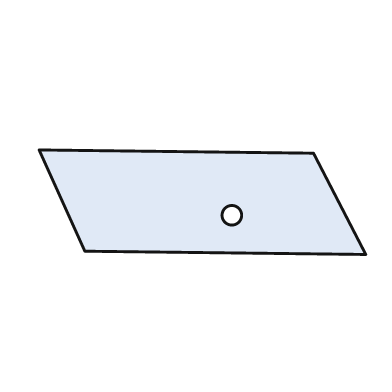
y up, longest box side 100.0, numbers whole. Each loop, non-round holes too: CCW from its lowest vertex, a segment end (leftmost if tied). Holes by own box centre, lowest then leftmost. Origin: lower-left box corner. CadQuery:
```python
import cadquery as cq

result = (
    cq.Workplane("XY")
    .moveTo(100.0, 0.0)
    .lineTo(84.0, 31.0)
    .lineTo(0.0, 32.0)
    .lineTo(14.0, 1.0)
    .close()
    .moveTo(59.0, 12.0)
    .circle(3.0)
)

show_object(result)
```